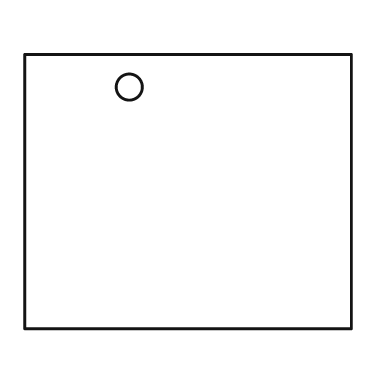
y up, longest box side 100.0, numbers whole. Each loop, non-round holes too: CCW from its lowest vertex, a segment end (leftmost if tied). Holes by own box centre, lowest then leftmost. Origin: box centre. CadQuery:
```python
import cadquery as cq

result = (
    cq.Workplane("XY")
    .moveTo(-50.0, -42.0)
    .lineTo(50.0, -42.0)
    .lineTo(50.0, 42.0)
    .lineTo(-50.0, 42.0)
    .close()
    .moveTo(-18.0, 32.0)
    .circle(4.0)
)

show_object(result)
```